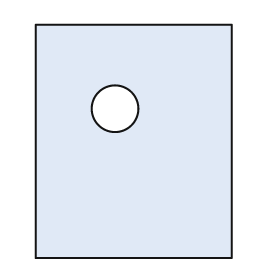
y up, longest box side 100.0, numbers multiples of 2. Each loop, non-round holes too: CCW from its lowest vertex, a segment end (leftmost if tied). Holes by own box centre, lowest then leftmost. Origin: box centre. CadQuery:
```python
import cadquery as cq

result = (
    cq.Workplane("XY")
    .moveTo(-42.0, -50.0)
    .lineTo(42.0, -50.0)
    .lineTo(42.0, 50.0)
    .lineTo(-42.0, 50.0)
    .close()
    .moveTo(-8.0, 14.0)
    .circle(10.0)
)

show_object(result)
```